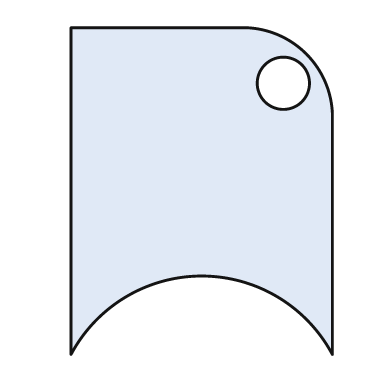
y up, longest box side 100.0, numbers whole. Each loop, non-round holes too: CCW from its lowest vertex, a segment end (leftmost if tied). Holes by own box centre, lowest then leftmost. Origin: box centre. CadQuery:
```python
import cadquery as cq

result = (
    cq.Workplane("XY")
    .moveTo(-40.0, -50.0)
    .threePointArc((0.0, -26.0), (40.0, -50.0))
    .lineTo(40.0, 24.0)
    .threePointArc((32.0, 42.0), (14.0, 50.0))
    .lineTo(-40.0, 50.0)
    .close()
    .moveTo(25.0, 33.0)
    .circle(8.0)
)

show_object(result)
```